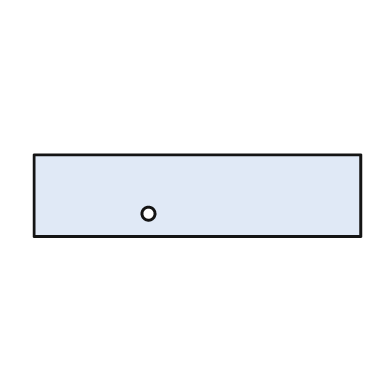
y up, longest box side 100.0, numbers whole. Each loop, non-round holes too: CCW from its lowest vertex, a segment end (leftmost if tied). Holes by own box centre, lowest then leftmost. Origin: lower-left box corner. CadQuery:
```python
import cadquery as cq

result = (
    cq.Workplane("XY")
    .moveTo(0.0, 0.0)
    .lineTo(100.0, 0.0)
    .lineTo(100.0, 25.0)
    .lineTo(0.0, 25.0)
    .close()
    .moveTo(35.0, 7.0)
    .circle(2.0)
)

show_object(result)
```